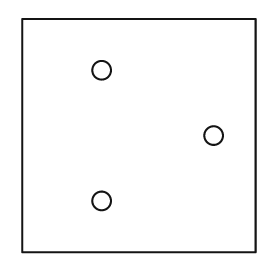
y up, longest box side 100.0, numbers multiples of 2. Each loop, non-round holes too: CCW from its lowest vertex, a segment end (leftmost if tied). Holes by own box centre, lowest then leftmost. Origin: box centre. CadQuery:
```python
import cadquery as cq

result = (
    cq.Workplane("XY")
    .moveTo(-50.0, -50.0)
    .lineTo(50.0, -50.0)
    .lineTo(50.0, 50.0)
    .lineTo(-50.0, 50.0)
    .close()
    .moveTo(-16.0, -28.0)
    .circle(4.0)
    .moveTo(32.0, 0.0)
    .circle(4.0)
    .moveTo(-16.0, 28.0)
    .circle(4.0)
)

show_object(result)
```